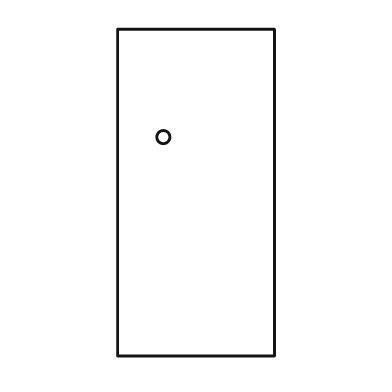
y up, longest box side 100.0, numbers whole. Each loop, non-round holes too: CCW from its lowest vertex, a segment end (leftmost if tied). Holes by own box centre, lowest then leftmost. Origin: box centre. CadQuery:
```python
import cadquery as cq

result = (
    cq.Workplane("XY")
    .moveTo(-24.0, -50.0)
    .lineTo(24.0, -50.0)
    .lineTo(24.0, 50.0)
    .lineTo(-24.0, 50.0)
    .close()
    .moveTo(-10.0, 17.0)
    .circle(2.0)
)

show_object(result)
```